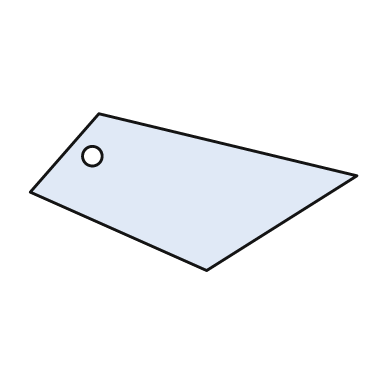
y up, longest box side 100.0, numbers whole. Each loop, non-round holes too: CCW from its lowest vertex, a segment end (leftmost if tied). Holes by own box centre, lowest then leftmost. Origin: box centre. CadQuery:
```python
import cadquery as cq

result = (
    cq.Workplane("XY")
    .moveTo(4.0, -24.0)
    .lineTo(50.0, 5.0)
    .lineTo(-29.0, 24.0)
    .lineTo(-50.0, 0.0)
    .close()
    .moveTo(-31.0, 11.0)
    .circle(3.0)
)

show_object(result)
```